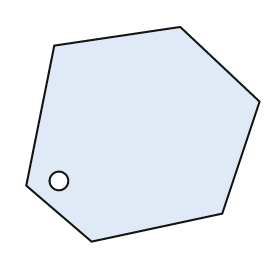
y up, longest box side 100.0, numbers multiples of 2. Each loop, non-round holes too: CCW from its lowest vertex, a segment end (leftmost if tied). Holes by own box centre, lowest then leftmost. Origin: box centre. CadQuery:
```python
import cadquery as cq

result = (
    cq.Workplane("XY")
    .moveTo(-22.0, -46.0)
    .lineTo(34.0, -34.0)
    .lineTo(50.0, 14.0)
    .lineTo(16.0, 46.0)
    .lineTo(-38.0, 38.0)
    .lineTo(-50.0, -22.0)
    .close()
    .moveTo(-36.0, -20.0)
    .circle(4.0)
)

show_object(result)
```